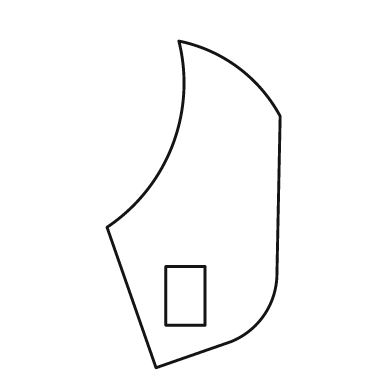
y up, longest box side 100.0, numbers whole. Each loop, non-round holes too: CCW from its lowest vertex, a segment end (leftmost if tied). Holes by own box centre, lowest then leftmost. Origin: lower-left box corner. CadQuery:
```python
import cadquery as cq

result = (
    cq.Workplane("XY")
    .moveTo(15.0, 0.0)
    .lineTo(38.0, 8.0)
    .threePointArc((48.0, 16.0), (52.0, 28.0))
    .lineTo(53.0, 77.0)
    .threePointArc((40.0, 92.0), (22.0, 100.0))
    .threePointArc((20.0, 68.0), (0.0, 43.0))
    .close()
    .moveTo(18.0, 13.0)
    .lineTo(30.0, 13.0)
    .lineTo(30.0, 31.0)
    .lineTo(18.0, 31.0)
    .close()
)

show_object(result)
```